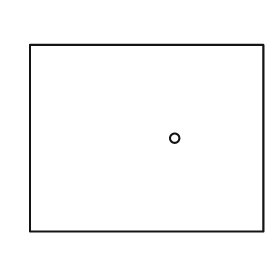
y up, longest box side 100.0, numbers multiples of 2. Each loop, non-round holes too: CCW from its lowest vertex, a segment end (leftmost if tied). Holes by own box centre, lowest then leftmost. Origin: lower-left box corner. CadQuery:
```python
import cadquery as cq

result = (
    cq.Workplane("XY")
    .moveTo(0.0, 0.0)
    .lineTo(100.0, 0.0)
    .lineTo(100.0, 80.0)
    .lineTo(0.0, 80.0)
    .close()
    .moveTo(62.0, 40.0)
    .circle(2.0)
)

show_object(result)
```